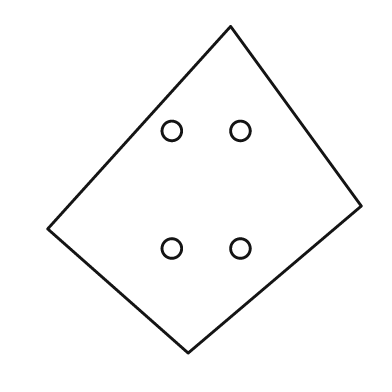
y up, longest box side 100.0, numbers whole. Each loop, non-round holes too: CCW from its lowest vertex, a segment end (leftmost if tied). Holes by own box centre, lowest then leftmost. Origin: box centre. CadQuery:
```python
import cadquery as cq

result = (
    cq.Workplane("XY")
    .moveTo(-5.0, -50.0)
    .lineTo(48.0, -5.0)
    .lineTo(8.0, 50.0)
    .lineTo(-48.0, -12.0)
    .close()
    .moveTo(-10.0, -18.0)
    .circle(3.0)
    .moveTo(11.0, -18.0)
    .circle(3.0)
    .moveTo(-10.0, 18.0)
    .circle(3.0)
    .moveTo(11.0, 18.0)
    .circle(3.0)
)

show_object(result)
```